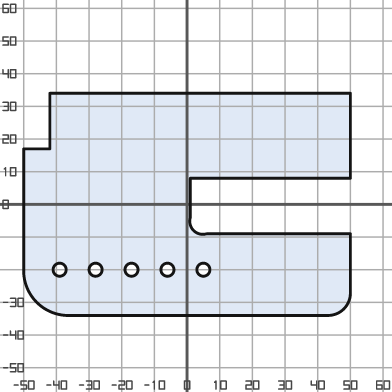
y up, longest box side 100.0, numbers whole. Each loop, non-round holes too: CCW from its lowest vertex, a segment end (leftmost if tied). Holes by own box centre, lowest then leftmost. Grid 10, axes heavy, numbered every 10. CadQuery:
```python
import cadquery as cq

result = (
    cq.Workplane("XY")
    .moveTo(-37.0, -34.0)
    .lineTo(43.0, -34.0)
    .threePointArc((48.0, -32.0), (50.0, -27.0))
    .lineTo(50.0, -9.0)
    .lineTo(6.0, -9.0)
    .threePointArc((2.0, -8.0), (1.0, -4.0))
    .lineTo(1.0, 8.0)
    .lineTo(50.0, 8.0)
    .lineTo(50.0, 34.0)
    .lineTo(-42.0, 34.0)
    .lineTo(-42.0, 17.0)
    .lineTo(-50.0, 17.0)
    .lineTo(-50.0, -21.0)
    .threePointArc((-46.0, -30.0), (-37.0, -34.0))
    .close()
    .moveTo(-39.0, -20.0)
    .circle(2.0)
    .moveTo(-28.0, -20.0)
    .circle(2.0)
    .moveTo(-17.0, -20.0)
    .circle(2.0)
    .moveTo(-6.0, -20.0)
    .circle(2.0)
    .moveTo(5.0, -20.0)
    .circle(2.0)
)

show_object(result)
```